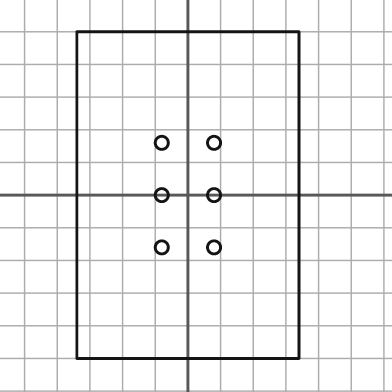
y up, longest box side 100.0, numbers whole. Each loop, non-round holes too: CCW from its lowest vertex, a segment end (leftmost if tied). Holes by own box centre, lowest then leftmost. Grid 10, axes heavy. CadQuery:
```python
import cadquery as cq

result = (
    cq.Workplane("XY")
    .moveTo(-34.0, -50.0)
    .lineTo(34.0, -50.0)
    .lineTo(34.0, 50.0)
    .lineTo(-34.0, 50.0)
    .close()
    .moveTo(-8.0, -16.0)
    .circle(2.0)
    .moveTo(8.0, -16.0)
    .circle(2.0)
    .moveTo(-8.0, 0.0)
    .circle(2.0)
    .moveTo(8.0, 0.0)
    .circle(2.0)
    .moveTo(-8.0, 16.0)
    .circle(2.0)
    .moveTo(8.0, 16.0)
    .circle(2.0)
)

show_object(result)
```